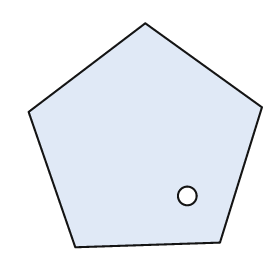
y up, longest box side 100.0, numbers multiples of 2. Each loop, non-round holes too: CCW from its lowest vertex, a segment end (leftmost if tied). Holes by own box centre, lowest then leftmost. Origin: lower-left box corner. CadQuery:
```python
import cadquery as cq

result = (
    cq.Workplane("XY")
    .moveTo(20.0, 0.0)
    .lineTo(82.0, 2.0)
    .lineTo(100.0, 60.0)
    .lineTo(50.0, 96.0)
    .lineTo(0.0, 58.0)
    .close()
    .moveTo(68.0, 22.0)
    .circle(4.0)
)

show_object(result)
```